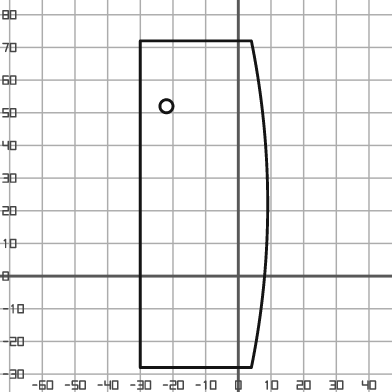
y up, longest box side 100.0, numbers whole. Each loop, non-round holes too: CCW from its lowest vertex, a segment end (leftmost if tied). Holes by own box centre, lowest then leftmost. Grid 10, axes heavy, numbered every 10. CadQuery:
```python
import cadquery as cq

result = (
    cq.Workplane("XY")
    .moveTo(-30.0, -28.0)
    .lineTo(4.0, -28.0)
    .threePointArc((9.0, 22.0), (4.0, 72.0))
    .lineTo(-30.0, 72.0)
    .close()
    .moveTo(-22.0, 52.0)
    .circle(2.0)
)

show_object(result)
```